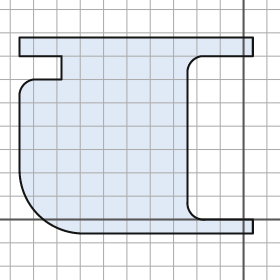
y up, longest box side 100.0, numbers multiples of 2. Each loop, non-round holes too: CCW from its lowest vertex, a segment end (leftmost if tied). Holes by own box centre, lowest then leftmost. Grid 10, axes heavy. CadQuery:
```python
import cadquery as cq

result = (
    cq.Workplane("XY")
    .moveTo(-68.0, -6.0)
    .lineTo(4.0, -6.0)
    .lineTo(4.0, 0.0)
    .lineTo(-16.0, 0.0)
    .threePointArc((-22.0, 2.0), (-24.0, 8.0))
    .lineTo(-24.0, 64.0)
    .threePointArc((-22.0, 68.0), (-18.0, 70.0))
    .lineTo(4.0, 70.0)
    .lineTo(4.0, 78.0)
    .lineTo(-96.0, 78.0)
    .lineTo(-96.0, 70.0)
    .lineTo(-78.0, 70.0)
    .lineTo(-78.0, 60.0)
    .lineTo(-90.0, 60.0)
    .threePointArc((-94.0, 58.0), (-96.0, 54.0))
    .lineTo(-96.0, 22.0)
    .threePointArc((-88.0, 2.0), (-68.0, -6.0))
    .close()
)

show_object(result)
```